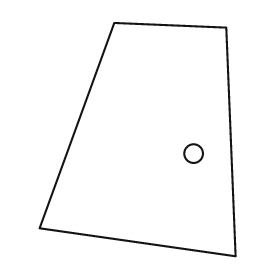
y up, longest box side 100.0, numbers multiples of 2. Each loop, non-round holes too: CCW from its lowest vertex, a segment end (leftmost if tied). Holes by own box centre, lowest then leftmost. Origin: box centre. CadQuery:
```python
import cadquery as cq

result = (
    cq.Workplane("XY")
    .moveTo(42.0, -50.0)
    .lineTo(38.0, 48.0)
    .lineTo(-10.0, 50.0)
    .lineTo(-42.0, -38.0)
    .close()
    .moveTo(24.0, -6.0)
    .circle(4.0)
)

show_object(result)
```